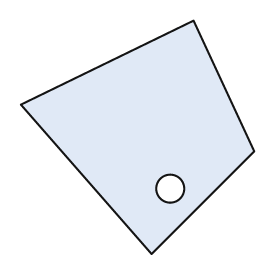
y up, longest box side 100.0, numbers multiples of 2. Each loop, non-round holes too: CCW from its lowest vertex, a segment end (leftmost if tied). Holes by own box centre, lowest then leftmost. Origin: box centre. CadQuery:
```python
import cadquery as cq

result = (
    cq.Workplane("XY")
    .moveTo(6.0, -50.0)
    .lineTo(50.0, -6.0)
    .lineTo(24.0, 50.0)
    .lineTo(-50.0, 14.0)
    .close()
    .moveTo(14.0, -22.0)
    .circle(6.0)
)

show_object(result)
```